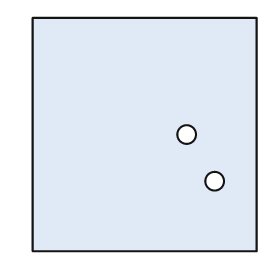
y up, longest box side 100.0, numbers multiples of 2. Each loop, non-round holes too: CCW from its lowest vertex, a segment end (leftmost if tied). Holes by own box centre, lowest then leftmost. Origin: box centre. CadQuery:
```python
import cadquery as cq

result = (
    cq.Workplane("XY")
    .moveTo(-48.0, -50.0)
    .lineTo(48.0, -50.0)
    .lineTo(48.0, 50.0)
    .lineTo(-48.0, 50.0)
    .close()
    .moveTo(30.0, -20.0)
    .circle(4.0)
    .moveTo(18.0, 0.0)
    .circle(4.0)
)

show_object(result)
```